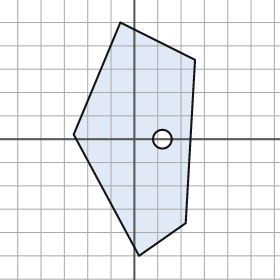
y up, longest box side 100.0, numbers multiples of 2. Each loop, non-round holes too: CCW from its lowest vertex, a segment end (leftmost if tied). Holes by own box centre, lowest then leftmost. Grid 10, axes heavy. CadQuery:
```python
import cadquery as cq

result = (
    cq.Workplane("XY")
    .moveTo(2.0, -50.0)
    .lineTo(22.0, -36.0)
    .lineTo(26.0, 34.0)
    .lineTo(-6.0, 50.0)
    .lineTo(-26.0, 2.0)
    .close()
    .moveTo(12.0, 0.0)
    .circle(4.0)
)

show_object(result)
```